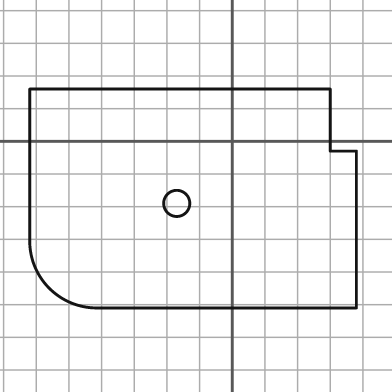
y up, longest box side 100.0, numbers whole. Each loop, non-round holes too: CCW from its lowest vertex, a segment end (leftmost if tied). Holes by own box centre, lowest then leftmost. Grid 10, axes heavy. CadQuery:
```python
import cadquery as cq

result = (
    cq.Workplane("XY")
    .moveTo(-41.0, -51.0)
    .lineTo(38.0, -51.0)
    .lineTo(38.0, -3.0)
    .lineTo(30.0, -3.0)
    .lineTo(30.0, 16.0)
    .lineTo(-62.0, 16.0)
    .lineTo(-62.0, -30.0)
    .threePointArc((-56.0, -45.0), (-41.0, -51.0))
    .close()
    .moveTo(-17.0, -19.0)
    .circle(4.0)
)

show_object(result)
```